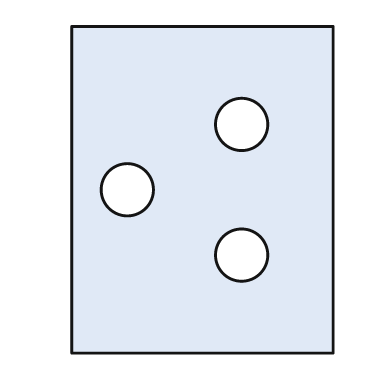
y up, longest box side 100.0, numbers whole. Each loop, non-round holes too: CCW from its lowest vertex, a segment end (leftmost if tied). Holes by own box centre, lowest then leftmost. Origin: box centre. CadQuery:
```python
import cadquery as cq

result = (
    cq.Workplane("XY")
    .moveTo(-40.0, -50.0)
    .lineTo(40.0, -50.0)
    .lineTo(40.0, 50.0)
    .lineTo(-40.0, 50.0)
    .close()
    .moveTo(12.0, -20.0)
    .circle(8.0)
    .moveTo(-23.0, 0.0)
    .circle(8.0)
    .moveTo(12.0, 20.0)
    .circle(8.0)
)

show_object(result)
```